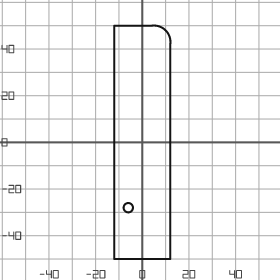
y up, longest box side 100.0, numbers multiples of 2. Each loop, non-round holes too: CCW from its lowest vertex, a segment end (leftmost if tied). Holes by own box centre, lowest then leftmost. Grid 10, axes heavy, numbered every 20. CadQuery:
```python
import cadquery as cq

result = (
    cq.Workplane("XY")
    .moveTo(-12.0, -50.0)
    .lineTo(12.0, -50.0)
    .lineTo(12.0, 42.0)
    .threePointArc((10.0, 48.0), (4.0, 50.0))
    .lineTo(-12.0, 50.0)
    .close()
    .moveTo(-6.0, -28.0)
    .circle(2.0)
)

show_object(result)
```